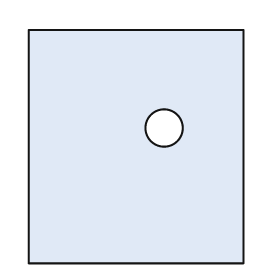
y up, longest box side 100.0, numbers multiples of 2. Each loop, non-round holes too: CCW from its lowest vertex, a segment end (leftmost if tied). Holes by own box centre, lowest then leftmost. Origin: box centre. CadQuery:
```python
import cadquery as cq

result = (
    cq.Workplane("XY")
    .moveTo(-46.0, -50.0)
    .lineTo(46.0, -50.0)
    .lineTo(46.0, 50.0)
    .lineTo(-46.0, 50.0)
    .close()
    .moveTo(12.0, 8.0)
    .circle(8.0)
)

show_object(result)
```